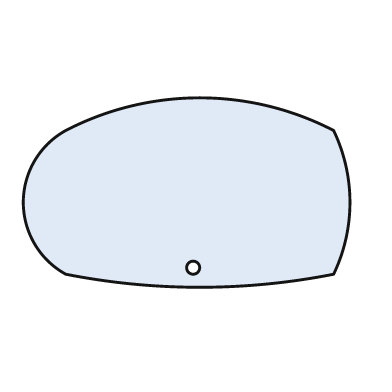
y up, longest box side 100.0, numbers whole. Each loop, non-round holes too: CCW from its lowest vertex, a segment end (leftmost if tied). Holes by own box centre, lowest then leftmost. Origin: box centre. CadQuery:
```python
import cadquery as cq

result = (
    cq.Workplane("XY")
    .moveTo(-37.0, -25.0)
    .threePointArc((4.0, -29.0), (45.0, -25.0))
    .threePointArc((50.0, -3.0), (45.0, 19.0))
    .threePointArc((4.0, 29.0), (-37.0, 19.0))
    .threePointArc((-50.0, -3.0), (-37.0, -25.0))
    .close()
    .moveTo(2.0, -23.0)
    .circle(2.0)
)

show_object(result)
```